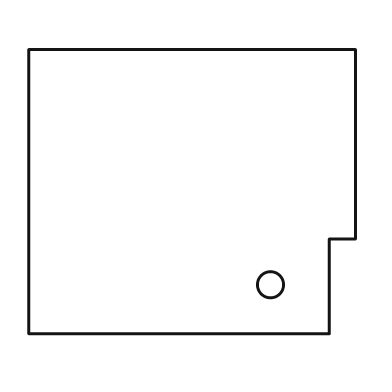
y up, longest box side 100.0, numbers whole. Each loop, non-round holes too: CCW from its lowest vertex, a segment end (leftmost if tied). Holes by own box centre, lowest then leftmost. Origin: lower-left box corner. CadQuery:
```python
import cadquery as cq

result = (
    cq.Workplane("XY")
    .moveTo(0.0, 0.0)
    .lineTo(92.0, 0.0)
    .lineTo(92.0, 29.0)
    .lineTo(100.0, 29.0)
    .lineTo(100.0, 87.0)
    .lineTo(0.0, 87.0)
    .close()
    .moveTo(74.0, 15.0)
    .circle(4.0)
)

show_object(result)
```